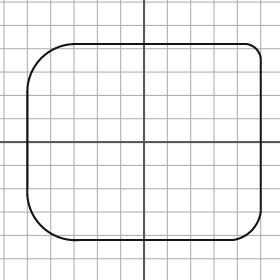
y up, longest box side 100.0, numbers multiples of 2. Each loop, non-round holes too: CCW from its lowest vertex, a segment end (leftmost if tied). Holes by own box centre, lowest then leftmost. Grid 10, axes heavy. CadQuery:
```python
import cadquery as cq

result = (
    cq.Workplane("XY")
    .moveTo(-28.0, -42.0)
    .lineTo(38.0, -42.0)
    .threePointArc((46.0, -38.0), (50.0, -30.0))
    .lineTo(50.0, 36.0)
    .threePointArc((48.0, 40.0), (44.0, 42.0))
    .lineTo(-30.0, 42.0)
    .threePointArc((-44.0, 36.0), (-50.0, 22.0))
    .lineTo(-50.0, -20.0)
    .threePointArc((-44.0, -36.0), (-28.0, -42.0))
    .close()
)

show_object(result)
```